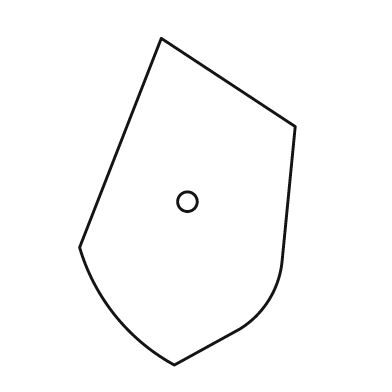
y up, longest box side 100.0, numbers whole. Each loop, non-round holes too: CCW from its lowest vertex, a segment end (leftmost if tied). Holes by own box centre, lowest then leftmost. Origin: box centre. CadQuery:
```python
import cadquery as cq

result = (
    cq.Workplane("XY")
    .moveTo(-4.0, -50.0)
    .lineTo(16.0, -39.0)
    .threePointArc((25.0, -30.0), (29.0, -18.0))
    .lineTo(33.0, 23.0)
    .lineTo(-8.0, 50.0)
    .lineTo(-33.0, -14.0)
    .threePointArc((-22.0, -35.0), (-4.0, -50.0))
    .close()
    .moveTo(0.0, 0.0)
    .circle(3.0)
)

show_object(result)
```